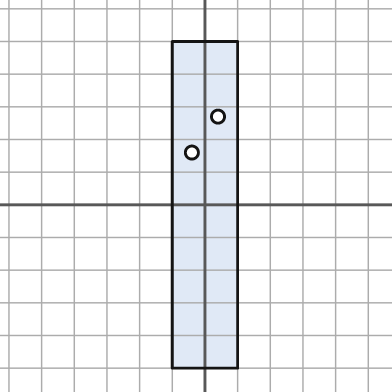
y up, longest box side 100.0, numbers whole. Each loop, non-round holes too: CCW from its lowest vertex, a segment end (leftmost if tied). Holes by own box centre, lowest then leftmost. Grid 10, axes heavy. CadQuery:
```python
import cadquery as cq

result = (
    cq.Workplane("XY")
    .moveTo(-10.0, -50.0)
    .lineTo(10.0, -50.0)
    .lineTo(10.0, 50.0)
    .lineTo(-10.0, 50.0)
    .close()
    .moveTo(-4.0, 16.0)
    .circle(2.0)
    .moveTo(4.0, 27.0)
    .circle(2.0)
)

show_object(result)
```